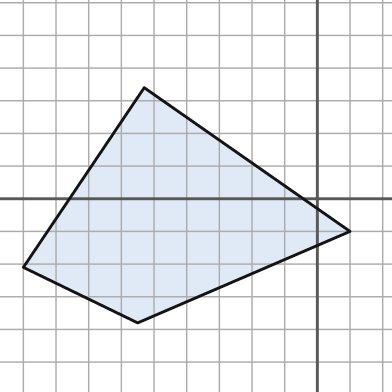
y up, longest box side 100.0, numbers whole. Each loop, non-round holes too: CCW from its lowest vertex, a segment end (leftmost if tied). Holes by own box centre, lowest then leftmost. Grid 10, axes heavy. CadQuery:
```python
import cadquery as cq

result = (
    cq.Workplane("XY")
    .moveTo(-55.0, -38.0)
    .lineTo(10.0, -10.0)
    .lineTo(-53.0, 34.0)
    .lineTo(-90.0, -21.0)
    .close()
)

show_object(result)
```